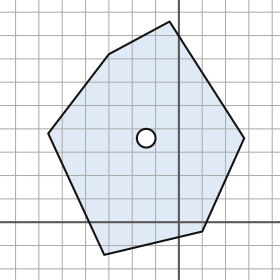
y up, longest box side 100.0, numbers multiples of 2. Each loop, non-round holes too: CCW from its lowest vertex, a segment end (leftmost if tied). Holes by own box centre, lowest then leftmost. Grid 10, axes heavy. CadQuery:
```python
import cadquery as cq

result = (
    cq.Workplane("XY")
    .moveTo(-32.0, -14.0)
    .lineTo(10.0, -4.0)
    .lineTo(28.0, 36.0)
    .lineTo(-4.0, 86.0)
    .lineTo(-30.0, 72.0)
    .lineTo(-56.0, 38.0)
    .close()
    .moveTo(-14.0, 36.0)
    .circle(4.0)
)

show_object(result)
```